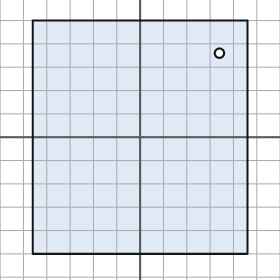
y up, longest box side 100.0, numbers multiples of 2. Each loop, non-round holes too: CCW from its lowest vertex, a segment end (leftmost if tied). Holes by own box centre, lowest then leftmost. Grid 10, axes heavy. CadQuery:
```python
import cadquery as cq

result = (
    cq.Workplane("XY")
    .moveTo(-46.0, -50.0)
    .lineTo(46.0, -50.0)
    .lineTo(46.0, 50.0)
    .lineTo(-46.0, 50.0)
    .close()
    .moveTo(34.0, 36.0)
    .circle(2.0)
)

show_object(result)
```